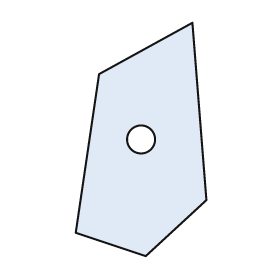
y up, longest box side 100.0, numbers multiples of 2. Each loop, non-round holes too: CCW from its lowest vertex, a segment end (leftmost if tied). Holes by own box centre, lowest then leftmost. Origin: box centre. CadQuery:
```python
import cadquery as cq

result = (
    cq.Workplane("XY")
    .moveTo(2.0, -50.0)
    .lineTo(28.0, -26.0)
    .lineTo(22.0, 50.0)
    .lineTo(-18.0, 28.0)
    .lineTo(-28.0, -40.0)
    .close()
    .moveTo(0.0, 0.0)
    .circle(6.0)
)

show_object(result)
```